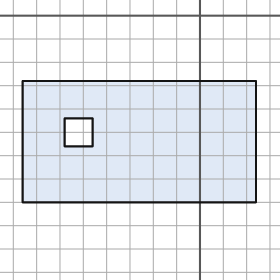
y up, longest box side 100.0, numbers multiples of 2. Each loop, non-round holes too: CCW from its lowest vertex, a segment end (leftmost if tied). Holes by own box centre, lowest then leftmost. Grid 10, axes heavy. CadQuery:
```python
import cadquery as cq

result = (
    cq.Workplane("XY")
    .moveTo(-76.0, -80.0)
    .lineTo(24.0, -80.0)
    .lineTo(24.0, -28.0)
    .lineTo(-76.0, -28.0)
    .close()
    .moveTo(-58.0, -56.0)
    .lineTo(-46.0, -56.0)
    .lineTo(-46.0, -44.0)
    .lineTo(-58.0, -44.0)
    .close()
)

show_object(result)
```